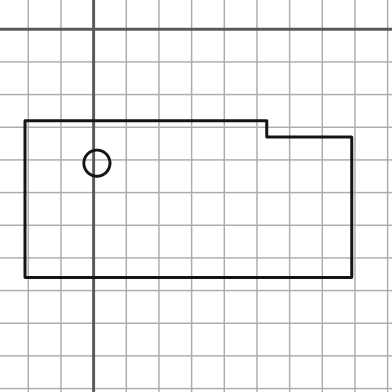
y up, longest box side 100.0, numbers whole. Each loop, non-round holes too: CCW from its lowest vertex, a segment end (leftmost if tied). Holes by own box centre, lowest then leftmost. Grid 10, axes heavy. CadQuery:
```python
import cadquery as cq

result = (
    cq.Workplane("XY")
    .moveTo(-21.0, -76.0)
    .lineTo(79.0, -76.0)
    .lineTo(79.0, -33.0)
    .lineTo(53.0, -33.0)
    .lineTo(53.0, -28.0)
    .lineTo(-21.0, -28.0)
    .close()
    .moveTo(1.0, -41.0)
    .circle(4.0)
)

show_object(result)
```